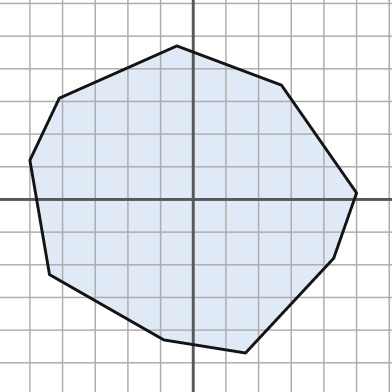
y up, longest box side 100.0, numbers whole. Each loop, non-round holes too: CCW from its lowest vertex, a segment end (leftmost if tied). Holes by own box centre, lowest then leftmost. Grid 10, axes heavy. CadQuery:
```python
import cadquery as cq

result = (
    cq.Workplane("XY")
    .moveTo(16.0, -47.0)
    .lineTo(43.0, -18.0)
    .lineTo(50.0, 2.0)
    .lineTo(27.0, 35.0)
    .lineTo(-5.0, 47.0)
    .lineTo(-41.0, 31.0)
    .lineTo(-50.0, 12.0)
    .lineTo(-44.0, -23.0)
    .lineTo(-9.0, -43.0)
    .close()
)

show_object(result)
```